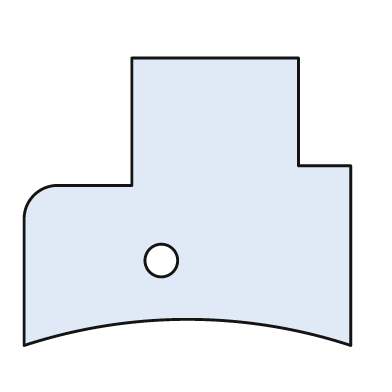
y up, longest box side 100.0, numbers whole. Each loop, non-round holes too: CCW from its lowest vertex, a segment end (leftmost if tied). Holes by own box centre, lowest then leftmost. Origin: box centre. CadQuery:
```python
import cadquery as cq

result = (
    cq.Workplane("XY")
    .moveTo(-50.0, -44.0)
    .threePointArc((0.0, -36.0), (50.0, -44.0))
    .lineTo(50.0, 11.0)
    .lineTo(34.0, 11.0)
    .lineTo(34.0, 44.0)
    .lineTo(-17.0, 44.0)
    .lineTo(-17.0, 5.0)
    .lineTo(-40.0, 5.0)
    .threePointArc((-47.0, 2.0), (-50.0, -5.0))
    .close()
    .moveTo(-8.0, -18.0)
    .circle(5.0)
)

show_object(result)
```